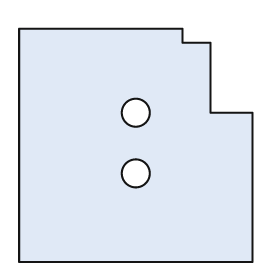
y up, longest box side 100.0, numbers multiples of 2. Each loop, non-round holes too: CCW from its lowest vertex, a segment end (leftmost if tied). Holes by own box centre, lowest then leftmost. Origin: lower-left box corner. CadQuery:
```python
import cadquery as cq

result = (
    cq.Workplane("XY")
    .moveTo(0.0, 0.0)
    .lineTo(100.0, 0.0)
    .lineTo(100.0, 64.0)
    .lineTo(82.0, 64.0)
    .lineTo(82.0, 94.0)
    .lineTo(70.0, 94.0)
    .lineTo(70.0, 100.0)
    .lineTo(0.0, 100.0)
    .close()
    .moveTo(50.0, 38.0)
    .circle(6.0)
    .moveTo(50.0, 64.0)
    .circle(6.0)
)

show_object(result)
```